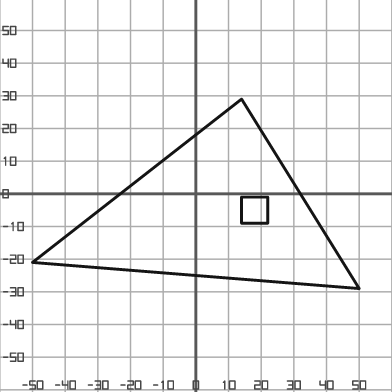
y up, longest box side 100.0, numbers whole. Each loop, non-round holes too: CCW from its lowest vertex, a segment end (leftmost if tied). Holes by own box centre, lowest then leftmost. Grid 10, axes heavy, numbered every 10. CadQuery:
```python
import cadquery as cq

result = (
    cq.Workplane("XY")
    .moveTo(50.0, -29.0)
    .lineTo(14.0, 29.0)
    .lineTo(-50.0, -21.0)
    .close()
    .moveTo(14.0, -9.0)
    .lineTo(22.0, -9.0)
    .lineTo(22.0, -1.0)
    .lineTo(14.0, -1.0)
    .close()
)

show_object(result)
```